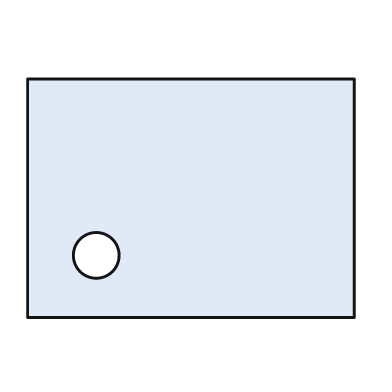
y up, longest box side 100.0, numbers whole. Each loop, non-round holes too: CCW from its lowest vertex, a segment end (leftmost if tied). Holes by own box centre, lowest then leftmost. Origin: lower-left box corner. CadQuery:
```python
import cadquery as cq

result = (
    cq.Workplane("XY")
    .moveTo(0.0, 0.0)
    .lineTo(100.0, 0.0)
    .lineTo(100.0, 73.0)
    .lineTo(0.0, 73.0)
    .close()
    .moveTo(21.0, 19.0)
    .circle(7.0)
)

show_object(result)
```